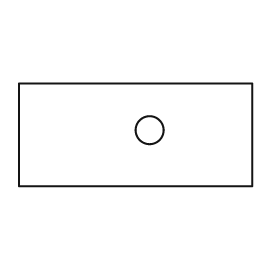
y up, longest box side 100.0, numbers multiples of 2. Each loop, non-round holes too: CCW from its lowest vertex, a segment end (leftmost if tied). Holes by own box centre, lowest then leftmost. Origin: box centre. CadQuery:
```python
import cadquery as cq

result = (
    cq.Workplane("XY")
    .moveTo(-50.0, -22.0)
    .lineTo(50.0, -22.0)
    .lineTo(50.0, 22.0)
    .lineTo(-50.0, 22.0)
    .close()
    .moveTo(6.0, 2.0)
    .circle(6.0)
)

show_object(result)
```